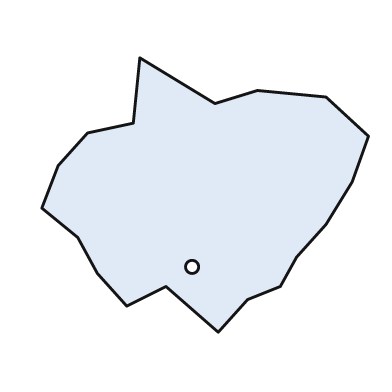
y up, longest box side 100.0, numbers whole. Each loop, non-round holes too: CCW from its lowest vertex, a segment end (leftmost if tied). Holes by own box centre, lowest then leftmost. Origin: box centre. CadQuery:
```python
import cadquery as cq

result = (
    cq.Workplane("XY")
    .moveTo(4.0, -42.0)
    .lineTo(13.0, -32.0)
    .lineTo(23.0, -28.0)
    .lineTo(28.0, -19.0)
    .lineTo(37.0, -9.0)
    .lineTo(45.0, 4.0)
    .lineTo(50.0, 18.0)
    .lineTo(37.0, 30.0)
    .lineTo(16.0, 32.0)
    .lineTo(3.0, 28.0)
    .lineTo(-20.0, 42.0)
    .lineTo(-22.0, 22.0)
    .lineTo(-36.0, 19.0)
    .lineTo(-45.0, 9.0)
    .lineTo(-50.0, -4.0)
    .lineTo(-39.0, -13.0)
    .lineTo(-33.0, -24.0)
    .lineTo(-24.0, -34.0)
    .lineTo(-12.0, -28.0)
    .close()
    .moveTo(-4.0, -22.0)
    .circle(2.0)
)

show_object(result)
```